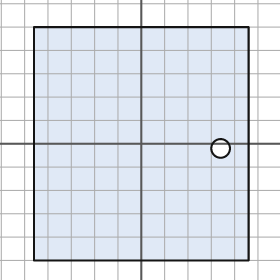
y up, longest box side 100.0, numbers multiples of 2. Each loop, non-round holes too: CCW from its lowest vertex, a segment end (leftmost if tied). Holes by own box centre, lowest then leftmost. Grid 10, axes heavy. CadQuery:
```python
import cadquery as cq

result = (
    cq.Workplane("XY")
    .moveTo(-46.0, -50.0)
    .lineTo(46.0, -50.0)
    .lineTo(46.0, 50.0)
    .lineTo(-46.0, 50.0)
    .close()
    .moveTo(34.0, -2.0)
    .circle(4.0)
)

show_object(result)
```